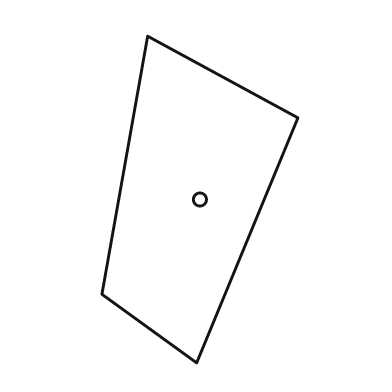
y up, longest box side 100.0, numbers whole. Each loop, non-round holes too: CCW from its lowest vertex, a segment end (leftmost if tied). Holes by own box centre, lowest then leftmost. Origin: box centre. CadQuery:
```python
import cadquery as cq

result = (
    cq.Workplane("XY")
    .moveTo(-1.0, -50.0)
    .lineTo(30.0, 25.0)
    .lineTo(-16.0, 50.0)
    .lineTo(-30.0, -29.0)
    .close()
    .moveTo(0.0, 0.0)
    .circle(2.0)
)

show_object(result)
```